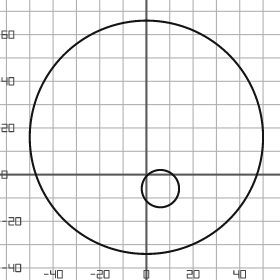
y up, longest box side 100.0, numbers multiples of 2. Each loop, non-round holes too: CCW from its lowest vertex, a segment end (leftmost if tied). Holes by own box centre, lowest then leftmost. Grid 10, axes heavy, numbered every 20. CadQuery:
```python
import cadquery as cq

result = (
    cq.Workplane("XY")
    .moveTo(0.0, 16.0)
    .circle(50.0)
    .moveTo(6.0, -6.0)
    .circle(8.0)
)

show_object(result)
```